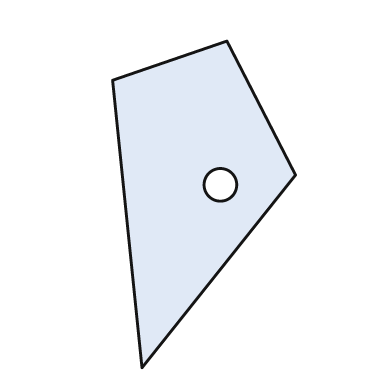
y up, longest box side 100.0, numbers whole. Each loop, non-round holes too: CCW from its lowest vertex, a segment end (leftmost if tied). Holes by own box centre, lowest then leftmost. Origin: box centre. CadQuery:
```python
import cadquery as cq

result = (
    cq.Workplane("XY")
    .moveTo(-19.0, -50.0)
    .lineTo(28.0, 9.0)
    .lineTo(7.0, 50.0)
    .lineTo(-28.0, 38.0)
    .close()
    .moveTo(5.0, 6.0)
    .circle(5.0)
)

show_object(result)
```